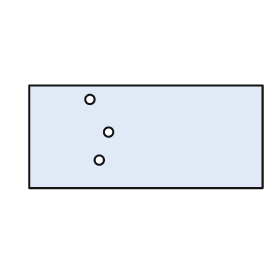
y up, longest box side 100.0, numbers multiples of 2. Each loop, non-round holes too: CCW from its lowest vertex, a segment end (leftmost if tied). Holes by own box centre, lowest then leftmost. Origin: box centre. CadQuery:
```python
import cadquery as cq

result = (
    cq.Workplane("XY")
    .moveTo(-50.0, -22.0)
    .lineTo(50.0, -22.0)
    .lineTo(50.0, 22.0)
    .lineTo(-50.0, 22.0)
    .close()
    .moveTo(-20.0, -10.0)
    .circle(2.0)
    .moveTo(-16.0, 2.0)
    .circle(2.0)
    .moveTo(-24.0, 16.0)
    .circle(2.0)
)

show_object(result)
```